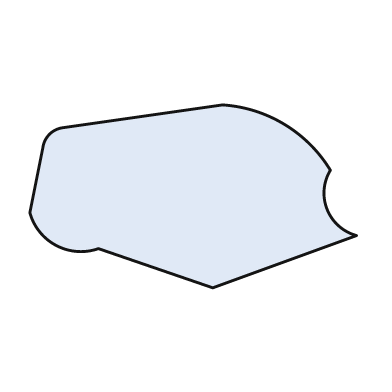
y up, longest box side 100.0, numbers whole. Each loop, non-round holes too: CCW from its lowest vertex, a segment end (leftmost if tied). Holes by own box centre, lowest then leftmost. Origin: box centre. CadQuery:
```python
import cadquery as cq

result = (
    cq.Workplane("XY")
    .moveTo(6.0, -28.0)
    .lineTo(50.0, -12.0)
    .threePointArc((41.0, -4.0), (42.0, 8.0))
    .threePointArc((28.0, 22.0), (9.0, 28.0))
    .lineTo(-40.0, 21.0)
    .threePointArc((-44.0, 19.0), (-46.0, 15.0))
    .lineTo(-50.0, -5.0)
    .threePointArc((-42.0, -15.0), (-29.0, -16.0))
    .close()
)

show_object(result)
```